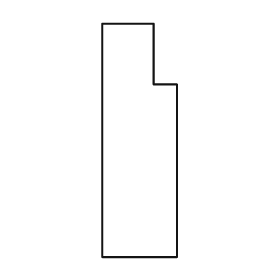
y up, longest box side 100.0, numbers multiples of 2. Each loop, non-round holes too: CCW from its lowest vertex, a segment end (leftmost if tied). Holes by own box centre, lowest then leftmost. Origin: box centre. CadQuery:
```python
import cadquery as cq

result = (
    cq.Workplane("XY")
    .moveTo(-16.0, -50.0)
    .lineTo(16.0, -50.0)
    .lineTo(16.0, 24.0)
    .lineTo(6.0, 24.0)
    .lineTo(6.0, 50.0)
    .lineTo(-16.0, 50.0)
    .close()
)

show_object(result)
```